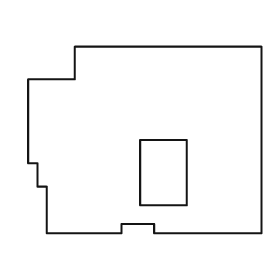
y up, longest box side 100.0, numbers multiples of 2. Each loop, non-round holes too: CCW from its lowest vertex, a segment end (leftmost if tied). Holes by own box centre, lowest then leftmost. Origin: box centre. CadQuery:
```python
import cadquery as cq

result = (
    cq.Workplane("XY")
    .moveTo(-42.0, -40.0)
    .lineTo(-10.0, -40.0)
    .lineTo(-10.0, -36.0)
    .lineTo(4.0, -36.0)
    .lineTo(4.0, -40.0)
    .lineTo(50.0, -40.0)
    .lineTo(50.0, 40.0)
    .lineTo(-30.0, 40.0)
    .lineTo(-30.0, 26.0)
    .lineTo(-50.0, 26.0)
    .lineTo(-50.0, -10.0)
    .lineTo(-46.0, -10.0)
    .lineTo(-46.0, -20.0)
    .lineTo(-42.0, -20.0)
    .close()
    .moveTo(-2.0, -28.0)
    .lineTo(18.0, -28.0)
    .lineTo(18.0, 0.0)
    .lineTo(-2.0, 0.0)
    .close()
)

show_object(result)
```